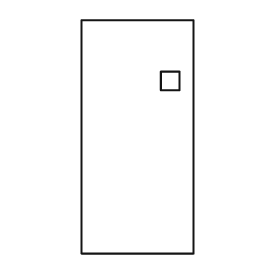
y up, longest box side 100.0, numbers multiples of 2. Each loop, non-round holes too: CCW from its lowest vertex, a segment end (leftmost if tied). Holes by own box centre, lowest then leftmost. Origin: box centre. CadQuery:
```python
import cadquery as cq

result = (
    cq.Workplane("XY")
    .moveTo(-24.0, -50.0)
    .lineTo(24.0, -50.0)
    .lineTo(24.0, 50.0)
    .lineTo(-24.0, 50.0)
    .close()
    .moveTo(10.0, 20.0)
    .lineTo(18.0, 20.0)
    .lineTo(18.0, 28.0)
    .lineTo(10.0, 28.0)
    .close()
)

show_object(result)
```